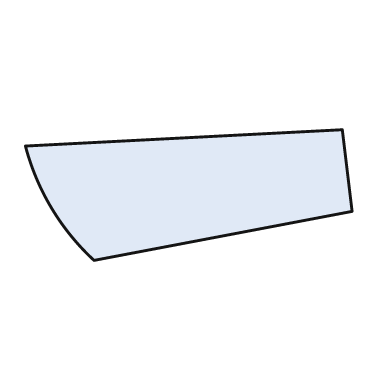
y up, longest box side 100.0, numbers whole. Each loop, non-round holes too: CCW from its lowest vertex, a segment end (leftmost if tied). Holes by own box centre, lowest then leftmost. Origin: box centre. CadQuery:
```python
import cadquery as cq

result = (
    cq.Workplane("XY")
    .moveTo(-29.0, -20.0)
    .lineTo(50.0, -5.0)
    .lineTo(47.0, 20.0)
    .lineTo(-50.0, 15.0)
    .threePointArc((-42.0, -4.0), (-29.0, -20.0))
    .close()
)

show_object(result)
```